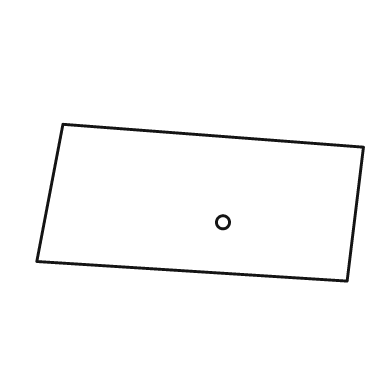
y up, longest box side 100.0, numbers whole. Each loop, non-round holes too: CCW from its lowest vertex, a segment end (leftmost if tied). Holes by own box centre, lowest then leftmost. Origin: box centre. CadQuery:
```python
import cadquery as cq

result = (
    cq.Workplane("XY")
    .moveTo(45.0, -24.0)
    .lineTo(50.0, 17.0)
    .lineTo(-42.0, 24.0)
    .lineTo(-50.0, -18.0)
    .close()
    .moveTo(7.0, -6.0)
    .circle(2.0)
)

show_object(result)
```